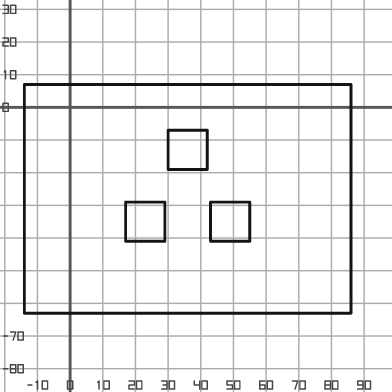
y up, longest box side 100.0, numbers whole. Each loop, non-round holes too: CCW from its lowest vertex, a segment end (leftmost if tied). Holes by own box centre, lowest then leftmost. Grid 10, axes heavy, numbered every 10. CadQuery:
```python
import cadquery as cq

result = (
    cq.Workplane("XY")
    .moveTo(-14.0, -63.0)
    .lineTo(86.0, -63.0)
    .lineTo(86.0, 7.0)
    .lineTo(-14.0, 7.0)
    .close()
    .moveTo(17.0, -41.0)
    .lineTo(29.0, -41.0)
    .lineTo(29.0, -29.0)
    .lineTo(17.0, -29.0)
    .close()
    .moveTo(43.0, -41.0)
    .lineTo(55.0, -41.0)
    .lineTo(55.0, -29.0)
    .lineTo(43.0, -29.0)
    .close()
    .moveTo(30.0, -19.0)
    .lineTo(42.0, -19.0)
    .lineTo(42.0, -7.0)
    .lineTo(30.0, -7.0)
    .close()
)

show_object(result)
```